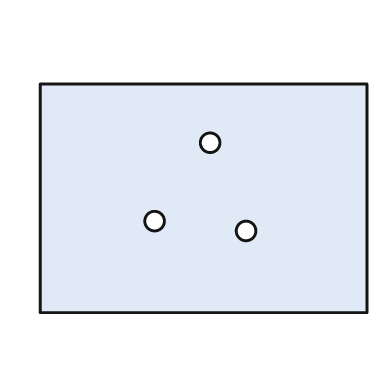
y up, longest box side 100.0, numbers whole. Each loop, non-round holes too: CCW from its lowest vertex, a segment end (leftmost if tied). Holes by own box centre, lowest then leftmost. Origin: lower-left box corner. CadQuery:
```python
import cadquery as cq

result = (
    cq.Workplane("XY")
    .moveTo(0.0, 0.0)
    .lineTo(100.0, 0.0)
    .lineTo(100.0, 70.0)
    .lineTo(0.0, 70.0)
    .close()
    .moveTo(63.0, 25.0)
    .circle(3.0)
    .moveTo(35.0, 28.0)
    .circle(3.0)
    .moveTo(52.0, 52.0)
    .circle(3.0)
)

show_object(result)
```